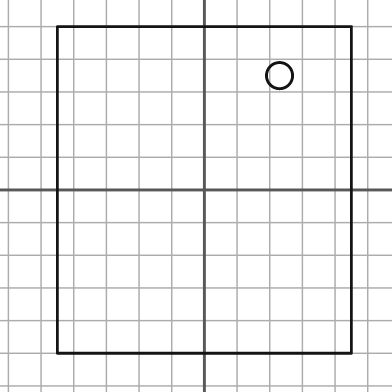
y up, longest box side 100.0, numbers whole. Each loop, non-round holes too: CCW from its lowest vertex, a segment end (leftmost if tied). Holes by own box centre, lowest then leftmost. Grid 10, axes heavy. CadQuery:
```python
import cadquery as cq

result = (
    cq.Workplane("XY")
    .moveTo(-45.0, -50.0)
    .lineTo(45.0, -50.0)
    .lineTo(45.0, 50.0)
    .lineTo(-45.0, 50.0)
    .close()
    .moveTo(23.0, 35.0)
    .circle(4.0)
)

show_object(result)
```